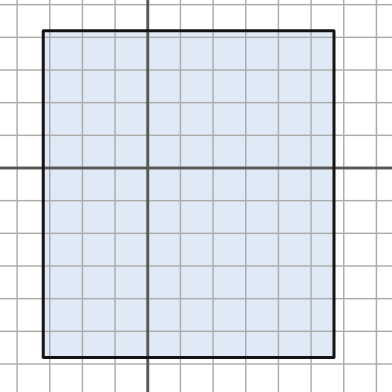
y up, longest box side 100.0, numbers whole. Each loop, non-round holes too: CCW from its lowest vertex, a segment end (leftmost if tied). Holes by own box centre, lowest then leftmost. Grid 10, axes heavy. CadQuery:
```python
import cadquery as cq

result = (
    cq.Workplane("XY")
    .moveTo(-32.0, -58.0)
    .lineTo(57.0, -58.0)
    .lineTo(57.0, 42.0)
    .lineTo(-32.0, 42.0)
    .close()
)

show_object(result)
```